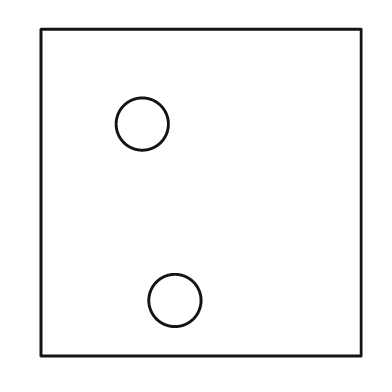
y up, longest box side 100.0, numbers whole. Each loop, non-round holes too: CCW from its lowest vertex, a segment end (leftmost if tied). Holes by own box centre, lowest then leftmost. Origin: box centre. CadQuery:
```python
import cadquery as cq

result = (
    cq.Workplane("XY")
    .moveTo(-49.0, -50.0)
    .lineTo(49.0, -50.0)
    .lineTo(49.0, 50.0)
    .lineTo(-49.0, 50.0)
    .close()
    .moveTo(-8.0, -33.0)
    .circle(8.0)
    .moveTo(-18.0, 21.0)
    .circle(8.0)
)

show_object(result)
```